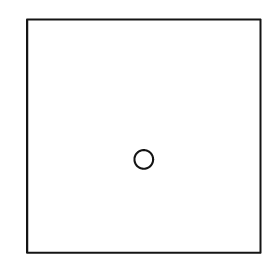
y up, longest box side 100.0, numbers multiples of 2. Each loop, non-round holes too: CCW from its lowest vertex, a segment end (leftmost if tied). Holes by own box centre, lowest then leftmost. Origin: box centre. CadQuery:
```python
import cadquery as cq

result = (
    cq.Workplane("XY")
    .moveTo(-50.0, -50.0)
    .lineTo(50.0, -50.0)
    .lineTo(50.0, 50.0)
    .lineTo(-50.0, 50.0)
    .close()
    .moveTo(0.0, -10.0)
    .circle(4.0)
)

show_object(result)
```